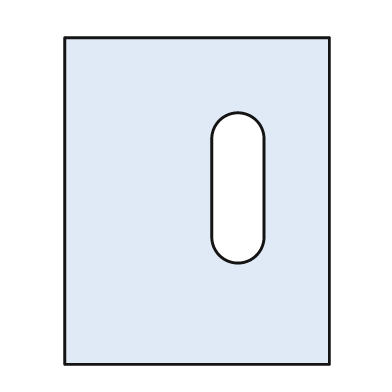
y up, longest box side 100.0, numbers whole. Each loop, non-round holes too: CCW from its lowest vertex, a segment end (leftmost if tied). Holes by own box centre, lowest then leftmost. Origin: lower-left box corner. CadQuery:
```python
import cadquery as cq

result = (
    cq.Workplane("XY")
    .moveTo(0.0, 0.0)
    .lineTo(81.0, 0.0)
    .lineTo(81.0, 100.0)
    .lineTo(0.0, 100.0)
    .close()
    .moveTo(45.0, 39.0)
    .threePointArc((53.0, 31.0), (61.0, 39.0))
    .lineTo(61.0, 69.0)
    .threePointArc((53.0, 77.0), (45.0, 69.0))
    .close()
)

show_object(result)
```